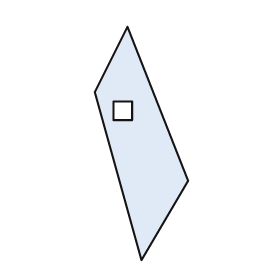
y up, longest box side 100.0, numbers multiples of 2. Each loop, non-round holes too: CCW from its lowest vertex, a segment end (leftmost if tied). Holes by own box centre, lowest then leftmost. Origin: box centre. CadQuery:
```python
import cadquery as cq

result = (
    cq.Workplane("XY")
    .moveTo(0.0, -50.0)
    .lineTo(20.0, -16.0)
    .lineTo(-6.0, 50.0)
    .lineTo(-20.0, 22.0)
    .close()
    .moveTo(-12.0, 10.0)
    .lineTo(-4.0, 10.0)
    .lineTo(-4.0, 18.0)
    .lineTo(-12.0, 18.0)
    .close()
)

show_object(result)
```